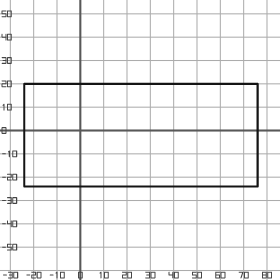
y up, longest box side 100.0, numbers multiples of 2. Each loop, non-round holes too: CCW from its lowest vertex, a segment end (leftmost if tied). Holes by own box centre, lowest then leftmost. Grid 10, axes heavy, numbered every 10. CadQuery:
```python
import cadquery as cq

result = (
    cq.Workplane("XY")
    .moveTo(-24.0, -24.0)
    .lineTo(76.0, -24.0)
    .lineTo(76.0, 20.0)
    .lineTo(-24.0, 20.0)
    .close()
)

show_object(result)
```